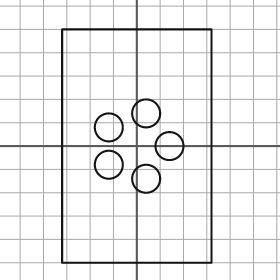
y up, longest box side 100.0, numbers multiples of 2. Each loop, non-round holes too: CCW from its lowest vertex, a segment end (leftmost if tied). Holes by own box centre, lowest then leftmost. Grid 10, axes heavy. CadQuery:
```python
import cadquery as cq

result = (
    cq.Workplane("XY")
    .moveTo(-32.0, -50.0)
    .lineTo(32.0, -50.0)
    .lineTo(32.0, 50.0)
    .lineTo(-32.0, 50.0)
    .close()
    .moveTo(4.0, -14.0)
    .circle(6.0)
    .moveTo(-12.0, -8.0)
    .circle(6.0)
    .moveTo(14.0, 0.0)
    .circle(6.0)
    .moveTo(-12.0, 8.0)
    .circle(6.0)
    .moveTo(4.0, 14.0)
    .circle(6.0)
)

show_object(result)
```